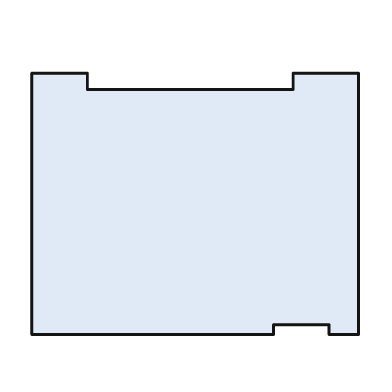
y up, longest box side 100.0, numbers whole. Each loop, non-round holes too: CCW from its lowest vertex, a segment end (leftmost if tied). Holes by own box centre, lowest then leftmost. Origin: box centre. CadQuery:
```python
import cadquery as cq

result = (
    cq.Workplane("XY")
    .moveTo(-50.0, -40.0)
    .lineTo(24.0, -40.0)
    .lineTo(24.0, -37.0)
    .lineTo(41.0, -37.0)
    .lineTo(41.0, -40.0)
    .lineTo(50.0, -40.0)
    .lineTo(50.0, 40.0)
    .lineTo(30.0, 40.0)
    .lineTo(30.0, 35.0)
    .lineTo(-33.0, 35.0)
    .lineTo(-33.0, 40.0)
    .lineTo(-50.0, 40.0)
    .close()
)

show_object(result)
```